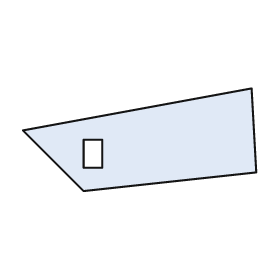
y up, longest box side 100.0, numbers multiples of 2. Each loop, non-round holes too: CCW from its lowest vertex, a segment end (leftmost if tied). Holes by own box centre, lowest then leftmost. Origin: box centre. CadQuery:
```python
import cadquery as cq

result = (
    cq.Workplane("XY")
    .moveTo(-24.0, -22.0)
    .lineTo(50.0, -14.0)
    .lineTo(48.0, 22.0)
    .lineTo(-50.0, 4.0)
    .close()
    .moveTo(-24.0, -12.0)
    .lineTo(-16.0, -12.0)
    .lineTo(-16.0, 0.0)
    .lineTo(-24.0, 0.0)
    .close()
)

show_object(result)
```